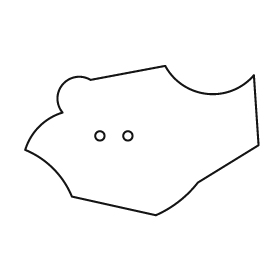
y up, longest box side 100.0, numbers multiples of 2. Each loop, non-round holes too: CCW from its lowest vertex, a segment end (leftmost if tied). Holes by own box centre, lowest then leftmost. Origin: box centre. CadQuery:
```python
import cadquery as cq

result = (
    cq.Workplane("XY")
    .moveTo(6.0, -32.0)
    .threePointArc((16.0, -26.0), (24.0, -18.0))
    .lineTo(50.0, -2.0)
    .lineTo(48.0, 28.0)
    .threePointArc((28.0, 20.0), (10.0, 32.0))
    .lineTo(-22.0, 26.0)
    .threePointArc((-34.0, 24.0), (-34.0, 12.0))
    .threePointArc((-44.0, 6.0), (-50.0, -4.0))
    .threePointArc((-38.0, -12.0), (-30.0, -24.0))
    .close()
    .moveTo(-18.0, 2.0)
    .circle(2.0)
    .moveTo(-6.0, 2.0)
    .circle(2.0)
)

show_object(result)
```